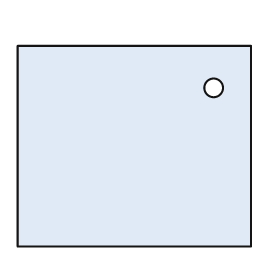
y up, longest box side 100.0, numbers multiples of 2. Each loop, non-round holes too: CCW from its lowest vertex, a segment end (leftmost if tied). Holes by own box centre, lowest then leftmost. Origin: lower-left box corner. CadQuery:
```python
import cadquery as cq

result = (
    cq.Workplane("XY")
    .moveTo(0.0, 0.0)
    .lineTo(100.0, 0.0)
    .lineTo(100.0, 86.0)
    .lineTo(0.0, 86.0)
    .close()
    .moveTo(84.0, 68.0)
    .circle(4.0)
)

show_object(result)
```